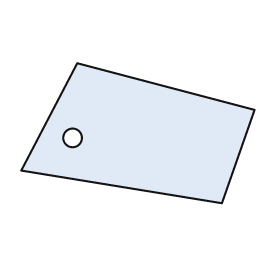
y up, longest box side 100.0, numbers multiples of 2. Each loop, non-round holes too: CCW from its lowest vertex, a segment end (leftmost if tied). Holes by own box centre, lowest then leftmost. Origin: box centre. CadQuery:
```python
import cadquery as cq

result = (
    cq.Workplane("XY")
    .moveTo(36.0, -30.0)
    .lineTo(50.0, 10.0)
    .lineTo(-26.0, 30.0)
    .lineTo(-50.0, -16.0)
    .close()
    .moveTo(-28.0, -2.0)
    .circle(4.0)
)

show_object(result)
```